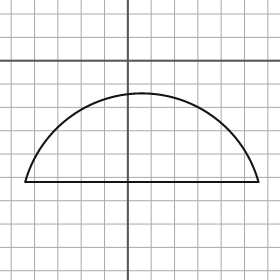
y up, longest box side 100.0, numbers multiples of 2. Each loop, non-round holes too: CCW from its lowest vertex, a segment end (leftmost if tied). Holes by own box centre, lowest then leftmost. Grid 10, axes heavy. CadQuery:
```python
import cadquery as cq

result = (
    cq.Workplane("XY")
    .moveTo(-44.0, -52.0)
    .lineTo(56.0, -52.0)
    .threePointArc((6.0, -14.0), (-44.0, -52.0))
    .close()
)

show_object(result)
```